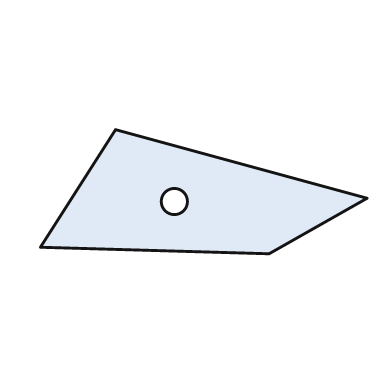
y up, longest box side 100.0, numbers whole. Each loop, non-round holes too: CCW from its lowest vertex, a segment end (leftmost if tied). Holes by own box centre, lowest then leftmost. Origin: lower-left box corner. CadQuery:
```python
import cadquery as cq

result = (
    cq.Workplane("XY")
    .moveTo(70.0, 0.0)
    .lineTo(100.0, 17.0)
    .lineTo(23.0, 38.0)
    .lineTo(0.0, 2.0)
    .close()
    .moveTo(41.0, 16.0)
    .circle(4.0)
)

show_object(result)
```